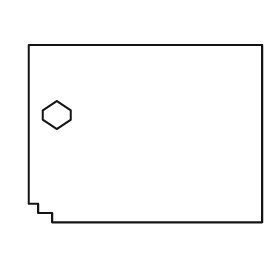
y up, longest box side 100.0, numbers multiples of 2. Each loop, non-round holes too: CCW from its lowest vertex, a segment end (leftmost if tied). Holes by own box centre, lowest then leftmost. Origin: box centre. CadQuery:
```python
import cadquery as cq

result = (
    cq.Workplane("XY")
    .moveTo(-40.0, -38.0)
    .lineTo(50.0, -38.0)
    .lineTo(50.0, 38.0)
    .lineTo(-50.0, 38.0)
    .lineTo(-50.0, -30.0)
    .lineTo(-46.0, -30.0)
    .lineTo(-46.0, -34.0)
    .lineTo(-40.0, -34.0)
    .close()
    .moveTo(-38.0, 2.0)
    .lineTo(-32.0, 6.0)
    .lineTo(-32.0, 10.0)
    .lineTo(-38.0, 14.0)
    .lineTo(-44.0, 10.0)
    .lineTo(-44.0, 6.0)
    .close()
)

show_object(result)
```